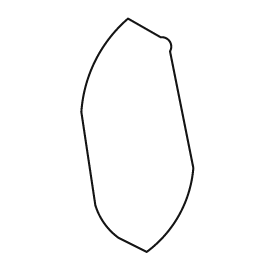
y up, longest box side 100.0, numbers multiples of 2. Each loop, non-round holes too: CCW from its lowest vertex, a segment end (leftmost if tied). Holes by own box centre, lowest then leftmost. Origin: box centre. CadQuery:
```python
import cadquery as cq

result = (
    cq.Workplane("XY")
    .moveTo(4.0, -50.0)
    .threePointArc((18.0, -34.0), (24.0, -14.0))
    .lineTo(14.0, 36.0)
    .threePointArc((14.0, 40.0), (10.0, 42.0))
    .lineTo(-4.0, 50.0)
    .threePointArc((-18.0, 32.0), (-24.0, 10.0))
    .lineTo(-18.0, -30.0)
    .threePointArc((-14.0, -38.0), (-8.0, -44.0))
    .close()
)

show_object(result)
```